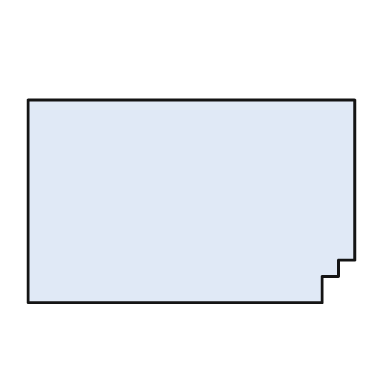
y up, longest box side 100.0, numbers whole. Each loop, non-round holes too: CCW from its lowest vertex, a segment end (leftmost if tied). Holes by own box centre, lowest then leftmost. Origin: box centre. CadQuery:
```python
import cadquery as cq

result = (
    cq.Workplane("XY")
    .moveTo(-50.0, -31.0)
    .lineTo(40.0, -31.0)
    .lineTo(40.0, -23.0)
    .lineTo(45.0, -23.0)
    .lineTo(45.0, -18.0)
    .lineTo(50.0, -18.0)
    .lineTo(50.0, 31.0)
    .lineTo(-50.0, 31.0)
    .close()
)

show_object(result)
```